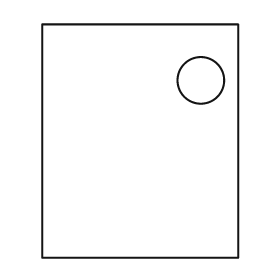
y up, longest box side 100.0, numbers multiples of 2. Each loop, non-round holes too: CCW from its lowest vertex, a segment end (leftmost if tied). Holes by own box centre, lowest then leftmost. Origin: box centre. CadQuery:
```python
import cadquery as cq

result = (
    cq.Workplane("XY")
    .moveTo(-42.0, -50.0)
    .lineTo(42.0, -50.0)
    .lineTo(42.0, 50.0)
    .lineTo(-42.0, 50.0)
    .close()
    .moveTo(26.0, 26.0)
    .circle(10.0)
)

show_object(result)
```